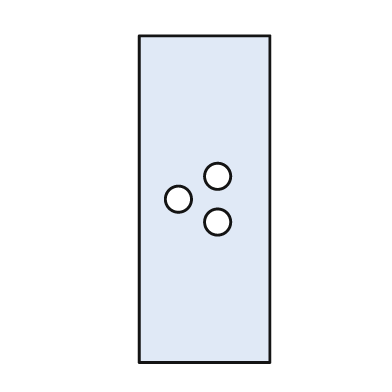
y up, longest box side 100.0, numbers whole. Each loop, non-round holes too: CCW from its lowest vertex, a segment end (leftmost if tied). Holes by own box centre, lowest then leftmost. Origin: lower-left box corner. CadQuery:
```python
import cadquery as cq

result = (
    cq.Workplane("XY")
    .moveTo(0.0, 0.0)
    .lineTo(40.0, 0.0)
    .lineTo(40.0, 100.0)
    .lineTo(0.0, 100.0)
    .close()
    .moveTo(24.0, 43.0)
    .circle(4.0)
    .moveTo(12.0, 50.0)
    .circle(4.0)
    .moveTo(24.0, 57.0)
    .circle(4.0)
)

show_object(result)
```